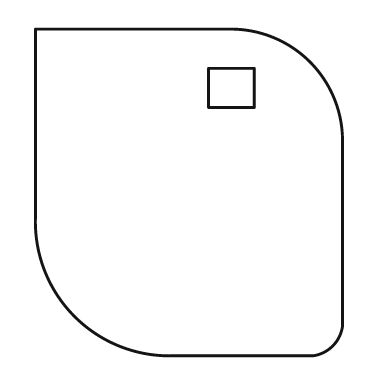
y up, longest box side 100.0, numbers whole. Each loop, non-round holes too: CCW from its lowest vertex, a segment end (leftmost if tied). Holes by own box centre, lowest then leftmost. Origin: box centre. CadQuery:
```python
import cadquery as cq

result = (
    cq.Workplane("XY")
    .moveTo(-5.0, -50.0)
    .lineTo(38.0, -50.0)
    .threePointArc((44.0, -47.0), (47.0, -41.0))
    .lineTo(47.0, 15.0)
    .threePointArc((37.0, 40.0), (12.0, 50.0))
    .lineTo(-47.0, 50.0)
    .lineTo(-47.0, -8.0)
    .threePointArc((-35.0, -38.0), (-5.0, -50.0))
    .close()
    .moveTo(6.0, 26.0)
    .lineTo(20.0, 26.0)
    .lineTo(20.0, 38.0)
    .lineTo(6.0, 38.0)
    .close()
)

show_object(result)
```